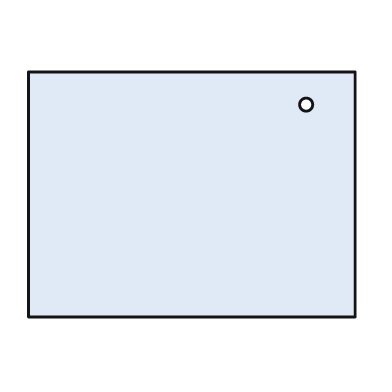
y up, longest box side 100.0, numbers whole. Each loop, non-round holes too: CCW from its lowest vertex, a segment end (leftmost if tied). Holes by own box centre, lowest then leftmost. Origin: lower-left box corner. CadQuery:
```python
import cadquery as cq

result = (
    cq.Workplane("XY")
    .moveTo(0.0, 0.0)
    .lineTo(100.0, 0.0)
    .lineTo(100.0, 75.0)
    .lineTo(0.0, 75.0)
    .close()
    .moveTo(85.0, 65.0)
    .circle(2.0)
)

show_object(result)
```